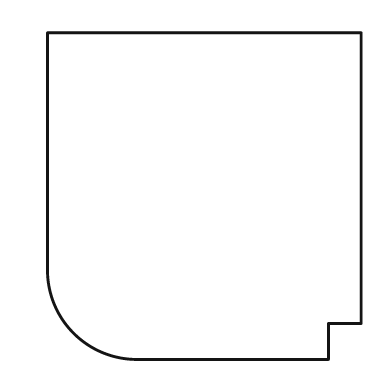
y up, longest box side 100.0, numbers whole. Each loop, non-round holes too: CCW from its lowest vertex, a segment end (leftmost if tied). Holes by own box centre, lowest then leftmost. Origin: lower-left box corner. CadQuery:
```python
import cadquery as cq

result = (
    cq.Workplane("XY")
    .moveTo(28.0, 0.0)
    .lineTo(86.0, 0.0)
    .lineTo(86.0, 11.0)
    .lineTo(96.0, 11.0)
    .lineTo(96.0, 100.0)
    .lineTo(0.0, 100.0)
    .lineTo(0.0, 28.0)
    .threePointArc((8.0, 8.0), (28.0, 0.0))
    .close()
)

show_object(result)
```